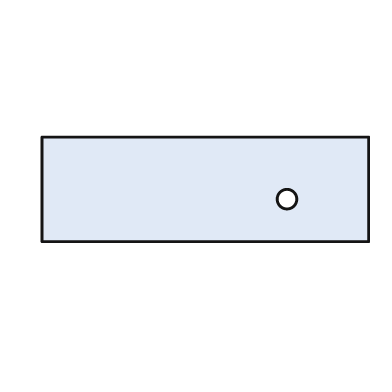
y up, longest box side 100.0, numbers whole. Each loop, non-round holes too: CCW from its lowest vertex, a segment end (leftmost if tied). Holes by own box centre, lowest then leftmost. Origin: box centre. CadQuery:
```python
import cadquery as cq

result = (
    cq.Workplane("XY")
    .moveTo(-50.0, -16.0)
    .lineTo(50.0, -16.0)
    .lineTo(50.0, 16.0)
    .lineTo(-50.0, 16.0)
    .close()
    .moveTo(25.0, -3.0)
    .circle(3.0)
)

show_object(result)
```